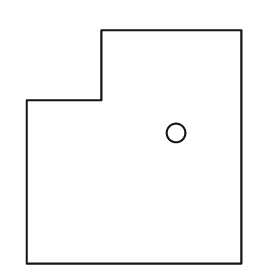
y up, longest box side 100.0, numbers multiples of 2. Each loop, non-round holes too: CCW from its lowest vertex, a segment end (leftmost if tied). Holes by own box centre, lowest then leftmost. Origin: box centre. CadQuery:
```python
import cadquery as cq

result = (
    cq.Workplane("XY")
    .moveTo(-46.0, -50.0)
    .lineTo(46.0, -50.0)
    .lineTo(46.0, 50.0)
    .lineTo(-14.0, 50.0)
    .lineTo(-14.0, 20.0)
    .lineTo(-46.0, 20.0)
    .close()
    .moveTo(18.0, 6.0)
    .circle(4.0)
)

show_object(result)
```